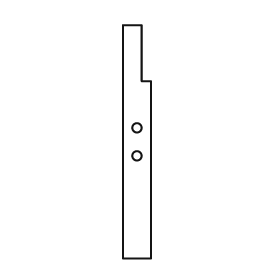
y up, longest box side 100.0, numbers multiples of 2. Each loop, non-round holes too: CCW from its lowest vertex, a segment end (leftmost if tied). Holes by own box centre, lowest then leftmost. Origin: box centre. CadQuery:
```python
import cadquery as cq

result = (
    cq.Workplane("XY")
    .moveTo(-6.0, -50.0)
    .lineTo(6.0, -50.0)
    .lineTo(6.0, 26.0)
    .lineTo(2.0, 26.0)
    .lineTo(2.0, 50.0)
    .lineTo(-6.0, 50.0)
    .close()
    .moveTo(0.0, -6.0)
    .circle(2.0)
    .moveTo(0.0, 6.0)
    .circle(2.0)
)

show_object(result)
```